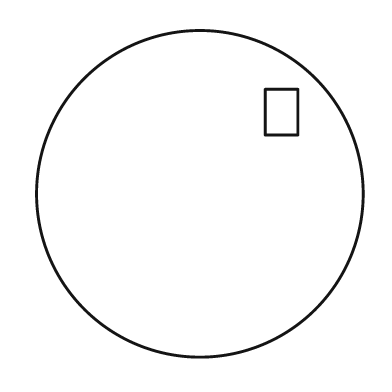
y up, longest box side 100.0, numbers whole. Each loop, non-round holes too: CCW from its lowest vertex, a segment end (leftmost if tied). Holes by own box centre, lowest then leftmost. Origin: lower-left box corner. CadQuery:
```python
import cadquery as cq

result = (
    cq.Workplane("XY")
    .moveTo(50.0, 50.0)
    .circle(50.0)
    .moveTo(70.0, 68.0)
    .lineTo(80.0, 68.0)
    .lineTo(80.0, 82.0)
    .lineTo(70.0, 82.0)
    .close()
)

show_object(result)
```